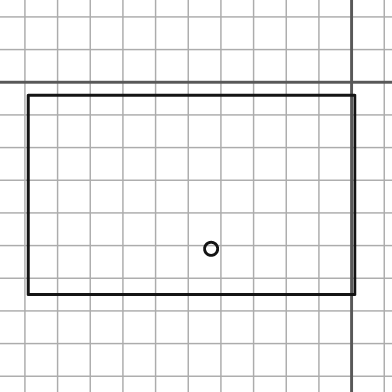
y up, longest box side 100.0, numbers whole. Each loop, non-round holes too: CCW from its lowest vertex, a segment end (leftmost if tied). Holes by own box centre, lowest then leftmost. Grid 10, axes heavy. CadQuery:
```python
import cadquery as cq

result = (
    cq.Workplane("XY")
    .moveTo(-99.0, -65.0)
    .lineTo(1.0, -65.0)
    .lineTo(1.0, -4.0)
    .lineTo(-99.0, -4.0)
    .close()
    .moveTo(-43.0, -51.0)
    .circle(2.0)
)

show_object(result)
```